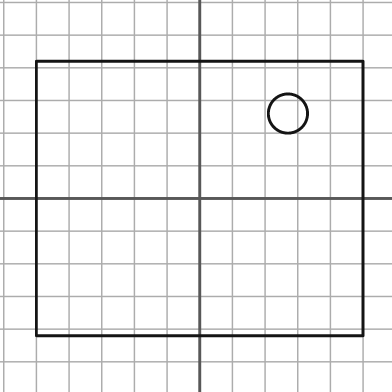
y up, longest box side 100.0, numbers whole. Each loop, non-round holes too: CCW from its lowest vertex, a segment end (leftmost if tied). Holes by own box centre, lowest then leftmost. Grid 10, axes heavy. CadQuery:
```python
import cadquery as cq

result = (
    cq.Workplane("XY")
    .moveTo(-50.0, -42.0)
    .lineTo(50.0, -42.0)
    .lineTo(50.0, 42.0)
    .lineTo(-50.0, 42.0)
    .close()
    .moveTo(27.0, 26.0)
    .circle(6.0)
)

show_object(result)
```